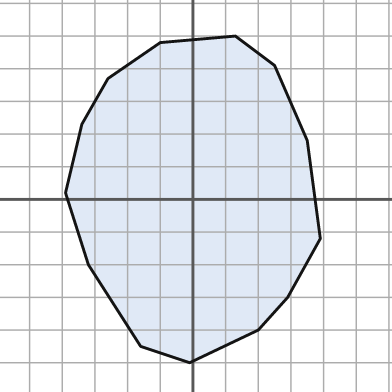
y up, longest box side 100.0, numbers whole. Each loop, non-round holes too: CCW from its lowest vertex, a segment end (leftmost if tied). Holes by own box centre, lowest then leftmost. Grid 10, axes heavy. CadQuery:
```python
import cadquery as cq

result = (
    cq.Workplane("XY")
    .moveTo(-1.0, -50.0)
    .lineTo(20.0, -40.0)
    .lineTo(29.0, -30.0)
    .lineTo(39.0, -12.0)
    .lineTo(35.0, 18.0)
    .lineTo(25.0, 41.0)
    .lineTo(13.0, 50.0)
    .lineTo(-10.0, 48.0)
    .lineTo(-26.0, 37.0)
    .lineTo(-34.0, 23.0)
    .lineTo(-39.0, 2.0)
    .lineTo(-32.0, -20.0)
    .lineTo(-16.0, -45.0)
    .close()
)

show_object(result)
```